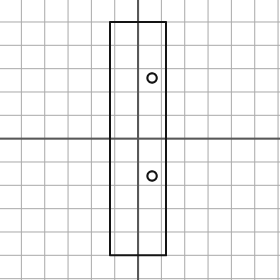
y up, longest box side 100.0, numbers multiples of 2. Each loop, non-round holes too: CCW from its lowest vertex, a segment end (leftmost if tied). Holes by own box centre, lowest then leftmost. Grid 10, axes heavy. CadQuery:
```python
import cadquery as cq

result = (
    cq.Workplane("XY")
    .moveTo(-12.0, -50.0)
    .lineTo(12.0, -50.0)
    .lineTo(12.0, 50.0)
    .lineTo(-12.0, 50.0)
    .close()
    .moveTo(6.0, -16.0)
    .circle(2.0)
    .moveTo(6.0, 26.0)
    .circle(2.0)
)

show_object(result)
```